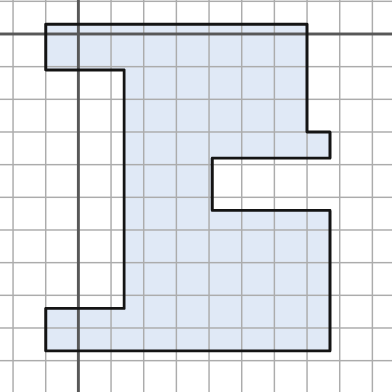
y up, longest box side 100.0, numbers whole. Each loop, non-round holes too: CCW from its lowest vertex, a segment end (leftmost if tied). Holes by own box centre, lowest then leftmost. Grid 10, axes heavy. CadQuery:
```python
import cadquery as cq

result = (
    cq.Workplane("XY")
    .moveTo(-10.0, -97.0)
    .lineTo(77.0, -97.0)
    .lineTo(77.0, -54.0)
    .lineTo(41.0, -54.0)
    .lineTo(41.0, -38.0)
    .lineTo(77.0, -38.0)
    .lineTo(77.0, -30.0)
    .lineTo(70.0, -30.0)
    .lineTo(70.0, 3.0)
    .lineTo(-10.0, 3.0)
    .lineTo(-10.0, -11.0)
    .lineTo(14.0, -11.0)
    .lineTo(14.0, -84.0)
    .lineTo(-10.0, -84.0)
    .close()
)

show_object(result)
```